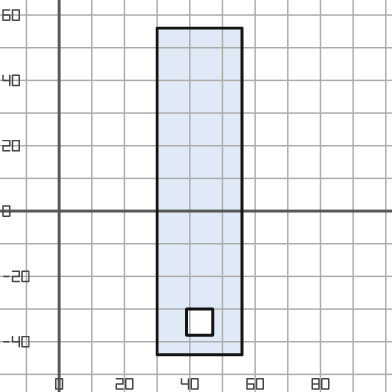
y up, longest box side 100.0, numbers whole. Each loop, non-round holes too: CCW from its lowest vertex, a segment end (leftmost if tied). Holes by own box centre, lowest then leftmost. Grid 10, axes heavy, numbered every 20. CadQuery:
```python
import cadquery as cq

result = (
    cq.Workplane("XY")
    .moveTo(30.0, -44.0)
    .lineTo(56.0, -44.0)
    .lineTo(56.0, 56.0)
    .lineTo(30.0, 56.0)
    .close()
    .moveTo(39.0, -38.0)
    .lineTo(47.0, -38.0)
    .lineTo(47.0, -30.0)
    .lineTo(39.0, -30.0)
    .close()
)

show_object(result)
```